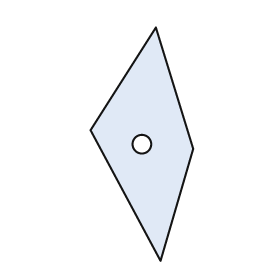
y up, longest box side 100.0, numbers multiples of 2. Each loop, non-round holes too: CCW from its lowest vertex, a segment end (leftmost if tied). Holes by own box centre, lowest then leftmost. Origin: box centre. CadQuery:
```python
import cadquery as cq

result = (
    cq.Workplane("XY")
    .moveTo(8.0, -50.0)
    .lineTo(22.0, -2.0)
    .lineTo(6.0, 50.0)
    .lineTo(-22.0, 6.0)
    .close()
    .moveTo(0.0, 0.0)
    .circle(4.0)
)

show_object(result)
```